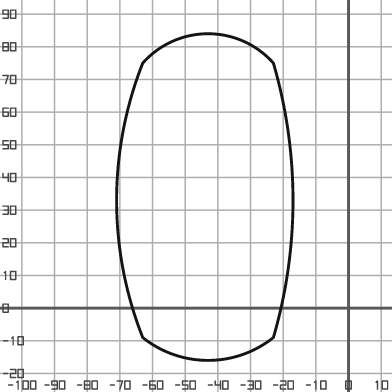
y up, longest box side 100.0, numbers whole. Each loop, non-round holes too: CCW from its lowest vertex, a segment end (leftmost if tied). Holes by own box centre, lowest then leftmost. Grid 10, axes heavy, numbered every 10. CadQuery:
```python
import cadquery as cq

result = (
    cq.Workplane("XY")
    .moveTo(-63.0, -9.0)
    .threePointArc((-43.0, -16.0), (-23.0, -9.0))
    .threePointArc((-17.0, 33.0), (-23.0, 75.0))
    .threePointArc((-43.0, 84.0), (-63.0, 75.0))
    .threePointArc((-71.0, 33.0), (-63.0, -9.0))
    .close()
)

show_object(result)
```